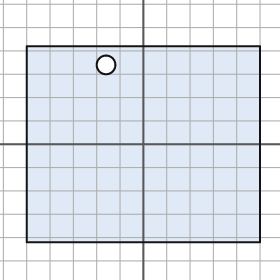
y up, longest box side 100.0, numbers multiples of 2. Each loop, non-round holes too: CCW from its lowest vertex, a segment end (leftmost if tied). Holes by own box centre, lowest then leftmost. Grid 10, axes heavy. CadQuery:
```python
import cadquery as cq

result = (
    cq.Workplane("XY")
    .moveTo(-50.0, -42.0)
    .lineTo(50.0, -42.0)
    .lineTo(50.0, 42.0)
    .lineTo(-50.0, 42.0)
    .close()
    .moveTo(-16.0, 34.0)
    .circle(4.0)
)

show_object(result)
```